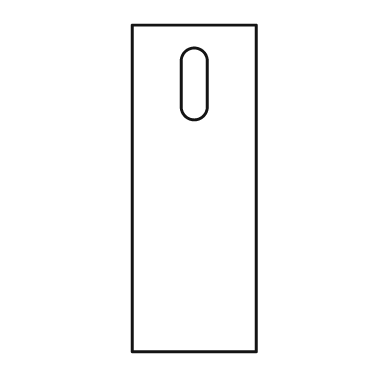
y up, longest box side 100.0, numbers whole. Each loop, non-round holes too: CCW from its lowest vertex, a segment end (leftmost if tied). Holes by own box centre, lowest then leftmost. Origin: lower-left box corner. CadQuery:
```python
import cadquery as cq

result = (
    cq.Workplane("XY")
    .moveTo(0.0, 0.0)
    .lineTo(38.0, 0.0)
    .lineTo(38.0, 100.0)
    .lineTo(0.0, 100.0)
    .close()
    .moveTo(15.0, 75.0)
    .threePointArc((19.0, 71.0), (23.0, 75.0))
    .lineTo(23.0, 89.0)
    .threePointArc((19.0, 93.0), (15.0, 89.0))
    .close()
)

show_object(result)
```